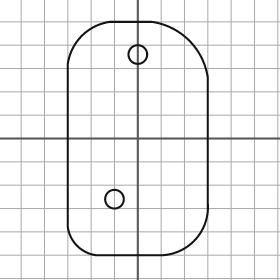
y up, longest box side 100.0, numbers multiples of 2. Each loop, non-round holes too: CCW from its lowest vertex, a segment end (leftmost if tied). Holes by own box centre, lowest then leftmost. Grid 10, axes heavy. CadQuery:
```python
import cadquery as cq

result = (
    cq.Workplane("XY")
    .moveTo(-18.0, -50.0)
    .lineTo(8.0, -50.0)
    .threePointArc((24.0, -44.0), (30.0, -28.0))
    .lineTo(30.0, 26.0)
    .threePointArc((22.0, 42.0), (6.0, 50.0))
    .lineTo(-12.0, 50.0)
    .threePointArc((-24.0, 44.0), (-30.0, 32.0))
    .lineTo(-30.0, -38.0)
    .threePointArc((-26.0, -46.0), (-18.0, -50.0))
    .close()
    .moveTo(-10.0, -26.0)
    .circle(4.0)
    .moveTo(0.0, 36.0)
    .circle(4.0)
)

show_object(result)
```